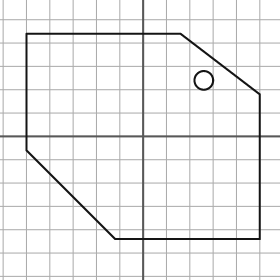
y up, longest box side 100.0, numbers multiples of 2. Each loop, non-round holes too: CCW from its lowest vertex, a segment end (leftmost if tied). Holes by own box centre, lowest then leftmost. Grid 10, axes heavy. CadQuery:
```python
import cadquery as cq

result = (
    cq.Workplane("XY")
    .moveTo(-12.0, -44.0)
    .lineTo(50.0, -44.0)
    .lineTo(50.0, 18.0)
    .lineTo(16.0, 44.0)
    .lineTo(-50.0, 44.0)
    .lineTo(-50.0, -6.0)
    .close()
    .moveTo(26.0, 24.0)
    .circle(4.0)
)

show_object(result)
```